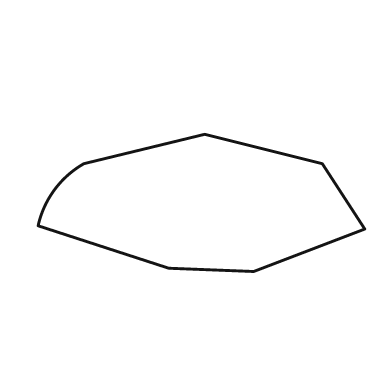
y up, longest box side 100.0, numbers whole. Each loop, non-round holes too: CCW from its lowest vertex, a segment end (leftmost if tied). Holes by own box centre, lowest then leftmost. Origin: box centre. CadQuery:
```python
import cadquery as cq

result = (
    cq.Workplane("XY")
    .moveTo(16.0, -21.0)
    .lineTo(50.0, -8.0)
    .lineTo(37.0, 12.0)
    .lineTo(1.0, 21.0)
    .lineTo(-36.0, 12.0)
    .threePointArc((-45.0, 4.0), (-50.0, -7.0))
    .lineTo(-10.0, -20.0)
    .close()
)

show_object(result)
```